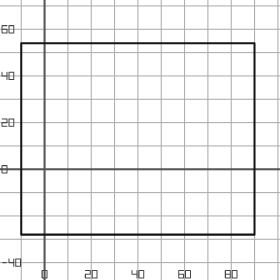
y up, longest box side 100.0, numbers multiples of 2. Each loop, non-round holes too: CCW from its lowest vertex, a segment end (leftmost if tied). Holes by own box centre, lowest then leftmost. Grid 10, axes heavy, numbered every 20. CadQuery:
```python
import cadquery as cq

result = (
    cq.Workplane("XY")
    .moveTo(-10.0, -28.0)
    .lineTo(90.0, -28.0)
    .lineTo(90.0, 54.0)
    .lineTo(-10.0, 54.0)
    .close()
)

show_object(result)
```